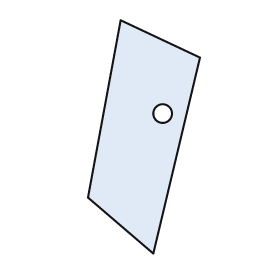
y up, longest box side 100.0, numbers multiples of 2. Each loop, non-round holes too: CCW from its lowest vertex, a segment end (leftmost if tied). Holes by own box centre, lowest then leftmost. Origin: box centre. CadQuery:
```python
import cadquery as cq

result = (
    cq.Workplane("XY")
    .moveTo(4.0, -50.0)
    .lineTo(24.0, 34.0)
    .lineTo(-10.0, 50.0)
    .lineTo(-24.0, -26.0)
    .close()
    .moveTo(8.0, 10.0)
    .circle(4.0)
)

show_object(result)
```